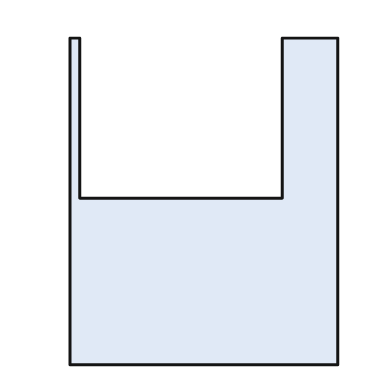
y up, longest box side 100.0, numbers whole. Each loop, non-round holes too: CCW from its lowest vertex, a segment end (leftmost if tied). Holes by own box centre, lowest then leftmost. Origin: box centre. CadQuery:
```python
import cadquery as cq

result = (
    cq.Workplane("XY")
    .moveTo(-41.0, -50.0)
    .lineTo(41.0, -50.0)
    .lineTo(41.0, 50.0)
    .lineTo(24.0, 50.0)
    .lineTo(24.0, 1.0)
    .lineTo(-38.0, 1.0)
    .lineTo(-38.0, 50.0)
    .lineTo(-41.0, 50.0)
    .close()
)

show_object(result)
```